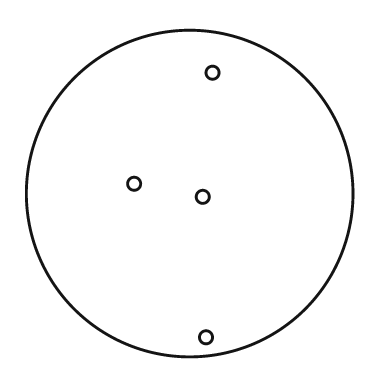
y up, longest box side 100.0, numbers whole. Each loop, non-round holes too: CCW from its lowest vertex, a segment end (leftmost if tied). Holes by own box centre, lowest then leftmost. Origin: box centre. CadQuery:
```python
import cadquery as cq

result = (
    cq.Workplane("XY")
    .moveTo(0.0, 0.0)
    .circle(50.0)
    .moveTo(5.0, -44.0)
    .circle(2.0)
    .moveTo(4.0, -1.0)
    .circle(2.0)
    .moveTo(-17.0, 3.0)
    .circle(2.0)
    .moveTo(7.0, 37.0)
    .circle(2.0)
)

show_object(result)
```